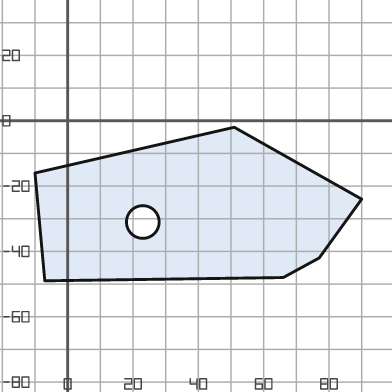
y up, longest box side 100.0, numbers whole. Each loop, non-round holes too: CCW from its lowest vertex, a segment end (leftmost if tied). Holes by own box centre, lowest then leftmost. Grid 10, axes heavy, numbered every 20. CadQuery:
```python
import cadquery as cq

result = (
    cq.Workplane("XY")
    .moveTo(-7.0, -49.0)
    .lineTo(66.0, -48.0)
    .lineTo(77.0, -42.0)
    .lineTo(90.0, -24.0)
    .lineTo(51.0, -2.0)
    .lineTo(-10.0, -16.0)
    .close()
    .moveTo(23.0, -31.0)
    .circle(5.0)
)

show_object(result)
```